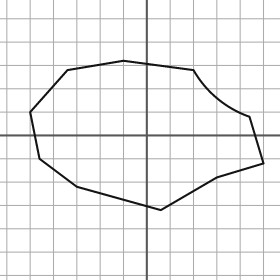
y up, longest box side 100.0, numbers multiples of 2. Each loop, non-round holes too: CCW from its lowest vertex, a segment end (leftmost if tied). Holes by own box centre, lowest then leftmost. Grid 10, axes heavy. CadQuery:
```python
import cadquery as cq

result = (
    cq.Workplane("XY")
    .moveTo(6.0, -32.0)
    .lineTo(30.0, -18.0)
    .lineTo(50.0, -12.0)
    .lineTo(44.0, 8.0)
    .threePointArc((30.0, 16.0), (20.0, 28.0))
    .lineTo(-10.0, 32.0)
    .lineTo(-34.0, 28.0)
    .lineTo(-50.0, 10.0)
    .lineTo(-46.0, -10.0)
    .lineTo(-30.0, -22.0)
    .close()
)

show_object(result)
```